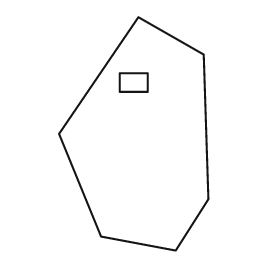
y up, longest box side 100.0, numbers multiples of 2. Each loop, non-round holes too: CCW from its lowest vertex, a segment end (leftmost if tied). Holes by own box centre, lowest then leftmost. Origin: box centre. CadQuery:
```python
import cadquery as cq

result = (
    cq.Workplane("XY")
    .moveTo(18.0, -50.0)
    .lineTo(32.0, -28.0)
    .lineTo(30.0, 34.0)
    .lineTo(2.0, 50.0)
    .lineTo(-32.0, 0.0)
    .lineTo(-14.0, -44.0)
    .close()
    .moveTo(-6.0, 18.0)
    .lineTo(6.0, 18.0)
    .lineTo(6.0, 26.0)
    .lineTo(-6.0, 26.0)
    .close()
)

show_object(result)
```